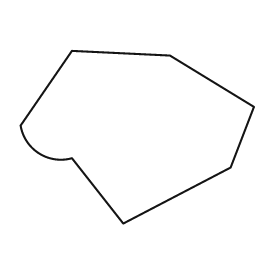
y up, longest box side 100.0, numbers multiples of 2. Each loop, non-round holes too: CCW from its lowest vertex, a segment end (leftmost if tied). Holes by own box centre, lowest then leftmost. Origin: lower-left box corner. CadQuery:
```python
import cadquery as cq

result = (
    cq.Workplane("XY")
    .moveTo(44.0, 0.0)
    .lineTo(90.0, 24.0)
    .lineTo(100.0, 50.0)
    .lineTo(64.0, 72.0)
    .lineTo(22.0, 74.0)
    .lineTo(0.0, 42.0)
    .threePointArc((8.0, 30.0), (22.0, 28.0))
    .close()
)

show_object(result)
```